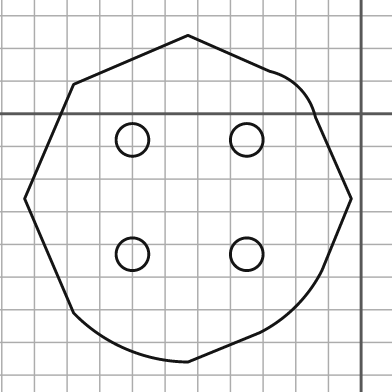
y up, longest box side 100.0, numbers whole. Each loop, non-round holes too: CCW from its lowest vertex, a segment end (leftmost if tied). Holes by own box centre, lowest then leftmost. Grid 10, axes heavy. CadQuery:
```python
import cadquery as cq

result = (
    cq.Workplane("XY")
    .moveTo(-53.0, -76.0)
    .lineTo(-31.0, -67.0)
    .threePointArc((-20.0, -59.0), (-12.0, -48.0))
    .lineTo(-3.0, -26.0)
    .lineTo(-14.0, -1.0)
    .threePointArc((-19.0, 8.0), (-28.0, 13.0))
    .lineTo(-53.0, 24.0)
    .lineTo(-88.0, 9.0)
    .lineTo(-103.0, -26.0)
    .lineTo(-88.0, -61.0)
    .threePointArc((-72.0, -72.0), (-53.0, -76.0))
    .close()
    .moveTo(-70.0, -43.0)
    .circle(5.0)
    .moveTo(-35.0, -43.0)
    .circle(5.0)
    .moveTo(-70.0, -8.0)
    .circle(5.0)
    .moveTo(-35.0, -8.0)
    .circle(5.0)
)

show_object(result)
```